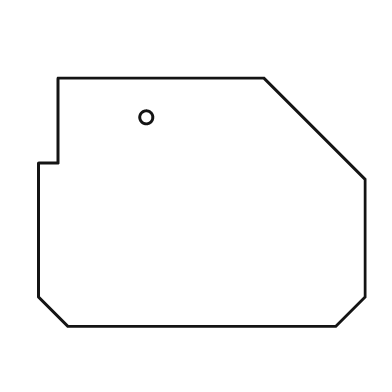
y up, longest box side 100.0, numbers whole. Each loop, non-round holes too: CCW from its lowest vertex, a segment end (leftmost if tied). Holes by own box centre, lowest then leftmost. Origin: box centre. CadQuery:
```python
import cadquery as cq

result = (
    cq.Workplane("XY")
    .moveTo(-41.0, -38.0)
    .lineTo(41.0, -38.0)
    .lineTo(50.0, -29.0)
    .lineTo(50.0, 7.0)
    .lineTo(19.0, 38.0)
    .lineTo(-44.0, 38.0)
    .lineTo(-44.0, 12.0)
    .lineTo(-50.0, 12.0)
    .lineTo(-50.0, -29.0)
    .close()
    .moveTo(-17.0, 26.0)
    .circle(2.0)
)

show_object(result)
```